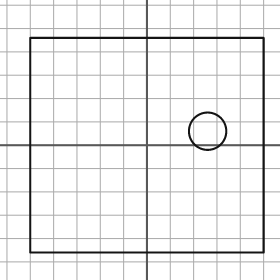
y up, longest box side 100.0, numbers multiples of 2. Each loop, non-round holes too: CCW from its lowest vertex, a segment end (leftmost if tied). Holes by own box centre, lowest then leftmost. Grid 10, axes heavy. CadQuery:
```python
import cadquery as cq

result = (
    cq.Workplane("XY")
    .moveTo(-50.0, -46.0)
    .lineTo(50.0, -46.0)
    .lineTo(50.0, 46.0)
    .lineTo(-50.0, 46.0)
    .close()
    .moveTo(26.0, 6.0)
    .circle(8.0)
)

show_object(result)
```